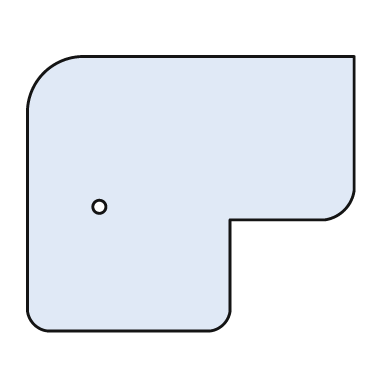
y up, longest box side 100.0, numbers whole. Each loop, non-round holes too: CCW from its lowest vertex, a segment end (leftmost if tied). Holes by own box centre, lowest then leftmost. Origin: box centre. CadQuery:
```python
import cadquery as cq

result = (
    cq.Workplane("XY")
    .moveTo(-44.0, -42.0)
    .lineTo(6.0, -42.0)
    .threePointArc((10.0, -40.0), (12.0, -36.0))
    .lineTo(12.0, -8.0)
    .lineTo(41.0, -8.0)
    .threePointArc((47.0, -5.0), (50.0, 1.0))
    .lineTo(50.0, 42.0)
    .lineTo(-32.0, 42.0)
    .threePointArc((-45.0, 37.0), (-50.0, 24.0))
    .lineTo(-50.0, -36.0)
    .threePointArc((-48.0, -40.0), (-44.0, -42.0))
    .close()
    .moveTo(-28.0, -4.0)
    .circle(2.0)
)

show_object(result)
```